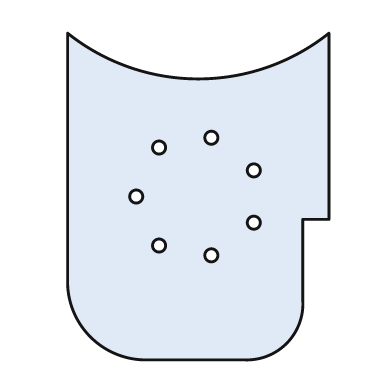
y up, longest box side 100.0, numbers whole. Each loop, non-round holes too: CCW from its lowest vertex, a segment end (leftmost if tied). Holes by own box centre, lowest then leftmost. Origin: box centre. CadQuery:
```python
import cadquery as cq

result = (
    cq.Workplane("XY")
    .moveTo(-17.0, -50.0)
    .lineTo(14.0, -50.0)
    .threePointArc((27.0, -45.0), (32.0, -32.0))
    .lineTo(32.0, -7.0)
    .lineTo(40.0, -7.0)
    .lineTo(40.0, 50.0)
    .threePointArc((0.0, 36.0), (-40.0, 50.0))
    .lineTo(-40.0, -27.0)
    .threePointArc((-33.0, -43.0), (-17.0, -50.0))
    .close()
    .moveTo(4.0, -18.0)
    .circle(2.0)
    .moveTo(-12.0, -15.0)
    .circle(2.0)
    .moveTo(17.0, -8.0)
    .circle(2.0)
    .moveTo(-19.0, 0.0)
    .circle(2.0)
    .moveTo(17.0, 8.0)
    .circle(2.0)
    .moveTo(-12.0, 15.0)
    .circle(2.0)
    .moveTo(4.0, 18.0)
    .circle(2.0)
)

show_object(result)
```